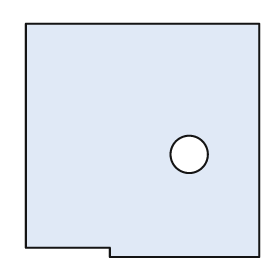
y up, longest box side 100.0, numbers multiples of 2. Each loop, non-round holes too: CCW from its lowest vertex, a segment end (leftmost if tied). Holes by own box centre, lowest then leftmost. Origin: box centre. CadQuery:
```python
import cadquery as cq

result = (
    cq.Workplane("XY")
    .moveTo(-14.0, -50.0)
    .lineTo(50.0, -50.0)
    .lineTo(50.0, 50.0)
    .lineTo(-50.0, 50.0)
    .lineTo(-50.0, -46.0)
    .lineTo(-14.0, -46.0)
    .close()
    .moveTo(20.0, -6.0)
    .circle(8.0)
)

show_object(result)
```